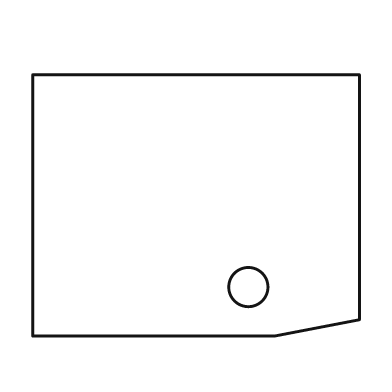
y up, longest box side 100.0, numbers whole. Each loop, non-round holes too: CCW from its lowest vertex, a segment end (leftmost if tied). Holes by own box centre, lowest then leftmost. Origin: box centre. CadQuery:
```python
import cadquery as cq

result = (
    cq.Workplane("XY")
    .moveTo(-50.0, -40.0)
    .lineTo(24.0, -40.0)
    .lineTo(50.0, -35.0)
    .lineTo(50.0, 40.0)
    .lineTo(-50.0, 40.0)
    .close()
    .moveTo(16.0, -25.0)
    .circle(6.0)
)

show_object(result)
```